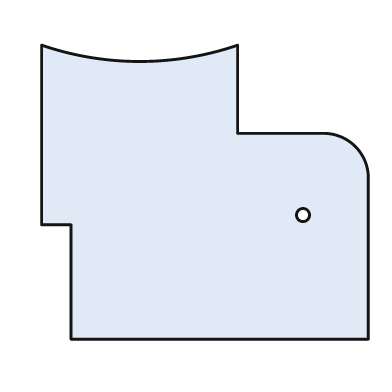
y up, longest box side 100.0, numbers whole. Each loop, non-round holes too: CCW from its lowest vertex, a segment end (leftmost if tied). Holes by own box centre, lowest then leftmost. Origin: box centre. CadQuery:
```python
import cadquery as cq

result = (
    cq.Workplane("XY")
    .moveTo(-41.0, -45.0)
    .lineTo(50.0, -45.0)
    .lineTo(50.0, 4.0)
    .threePointArc((46.0, 14.0), (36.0, 18.0))
    .lineTo(10.0, 18.0)
    .lineTo(10.0, 45.0)
    .threePointArc((-20.0, 40.0), (-50.0, 45.0))
    .lineTo(-50.0, -10.0)
    .lineTo(-41.0, -10.0)
    .close()
    .moveTo(30.0, -7.0)
    .circle(2.0)
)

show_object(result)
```